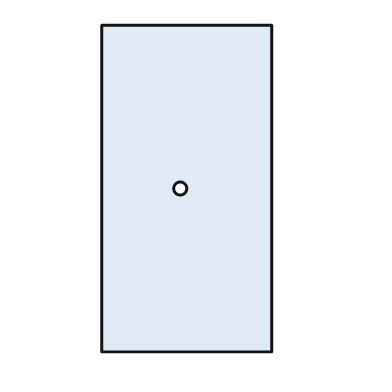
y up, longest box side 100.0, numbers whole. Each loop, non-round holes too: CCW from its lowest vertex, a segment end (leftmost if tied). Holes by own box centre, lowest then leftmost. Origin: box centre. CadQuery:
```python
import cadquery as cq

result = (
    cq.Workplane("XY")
    .moveTo(-26.0, -50.0)
    .lineTo(26.0, -50.0)
    .lineTo(26.0, 50.0)
    .lineTo(-26.0, 50.0)
    .close()
    .moveTo(-2.0, 0.0)
    .circle(2.0)
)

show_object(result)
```